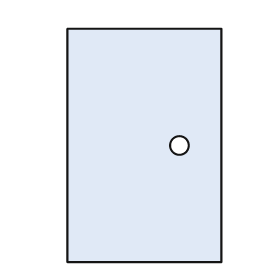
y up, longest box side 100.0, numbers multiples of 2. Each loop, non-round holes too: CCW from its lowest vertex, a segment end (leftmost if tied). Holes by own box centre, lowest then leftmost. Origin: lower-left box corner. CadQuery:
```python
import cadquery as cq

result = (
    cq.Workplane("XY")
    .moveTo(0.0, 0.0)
    .lineTo(66.0, 0.0)
    .lineTo(66.0, 100.0)
    .lineTo(0.0, 100.0)
    .close()
    .moveTo(48.0, 50.0)
    .circle(4.0)
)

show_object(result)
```